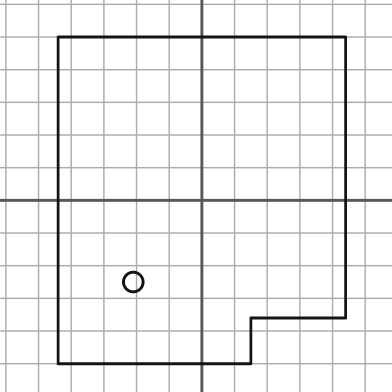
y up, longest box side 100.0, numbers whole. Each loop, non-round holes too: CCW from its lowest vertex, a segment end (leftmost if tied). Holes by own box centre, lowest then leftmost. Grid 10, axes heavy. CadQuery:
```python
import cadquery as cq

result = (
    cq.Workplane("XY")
    .moveTo(-44.0, -50.0)
    .lineTo(15.0, -50.0)
    .lineTo(15.0, -36.0)
    .lineTo(44.0, -36.0)
    .lineTo(44.0, 50.0)
    .lineTo(-44.0, 50.0)
    .close()
    .moveTo(-21.0, -25.0)
    .circle(3.0)
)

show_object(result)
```